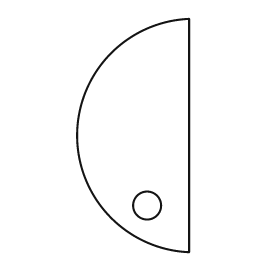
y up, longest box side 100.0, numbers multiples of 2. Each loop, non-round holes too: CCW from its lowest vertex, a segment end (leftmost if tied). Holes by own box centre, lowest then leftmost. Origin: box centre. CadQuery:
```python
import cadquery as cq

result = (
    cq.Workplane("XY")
    .moveTo(24.0, -50.0)
    .lineTo(24.0, 50.0)
    .threePointArc((-24.0, 0.0), (24.0, -50.0))
    .close()
    .moveTo(6.0, -30.0)
    .circle(6.0)
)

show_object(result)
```